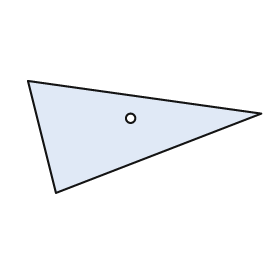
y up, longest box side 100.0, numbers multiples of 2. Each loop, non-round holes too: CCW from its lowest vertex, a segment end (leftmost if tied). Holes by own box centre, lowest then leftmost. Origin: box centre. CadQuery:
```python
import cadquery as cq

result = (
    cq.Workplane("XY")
    .moveTo(-38.0, -24.0)
    .lineTo(50.0, 10.0)
    .lineTo(-50.0, 24.0)
    .close()
    .moveTo(-6.0, 8.0)
    .circle(2.0)
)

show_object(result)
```